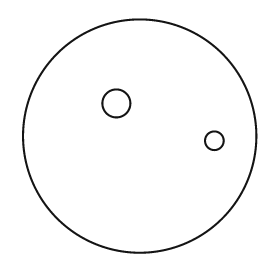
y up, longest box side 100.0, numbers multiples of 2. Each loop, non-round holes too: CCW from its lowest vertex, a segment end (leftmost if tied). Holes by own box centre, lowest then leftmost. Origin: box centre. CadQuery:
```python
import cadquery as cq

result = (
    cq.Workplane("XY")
    .moveTo(0.0, 0.0)
    .circle(50.0)
    .moveTo(32.0, -2.0)
    .circle(4.0)
    .moveTo(-10.0, 14.0)
    .circle(6.0)
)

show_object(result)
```